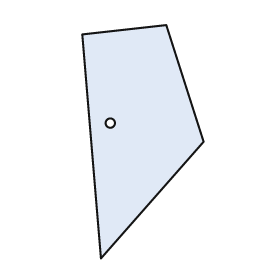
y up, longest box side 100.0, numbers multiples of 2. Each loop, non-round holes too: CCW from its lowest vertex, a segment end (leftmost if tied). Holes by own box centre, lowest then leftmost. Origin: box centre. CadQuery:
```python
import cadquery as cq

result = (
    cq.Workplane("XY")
    .moveTo(-18.0, -50.0)
    .lineTo(26.0, 0.0)
    .lineTo(10.0, 50.0)
    .lineTo(-26.0, 46.0)
    .close()
    .moveTo(-14.0, 8.0)
    .circle(2.0)
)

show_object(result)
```